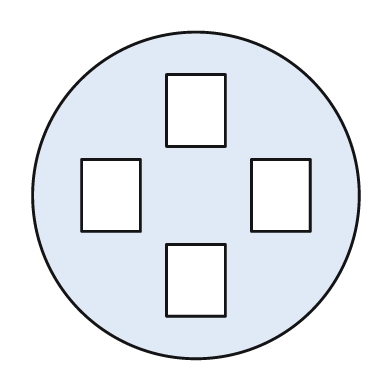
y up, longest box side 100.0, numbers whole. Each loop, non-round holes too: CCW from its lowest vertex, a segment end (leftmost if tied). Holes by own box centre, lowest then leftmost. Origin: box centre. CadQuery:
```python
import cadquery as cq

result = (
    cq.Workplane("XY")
    .moveTo(0.0, 0.0)
    .circle(50.0)
    .moveTo(-9.0, -37.0)
    .lineTo(9.0, -37.0)
    .lineTo(9.0, -15.0)
    .lineTo(-9.0, -15.0)
    .close()
    .moveTo(-35.0, -11.0)
    .lineTo(-17.0, -11.0)
    .lineTo(-17.0, 11.0)
    .lineTo(-35.0, 11.0)
    .close()
    .moveTo(17.0, -11.0)
    .lineTo(35.0, -11.0)
    .lineTo(35.0, 11.0)
    .lineTo(17.0, 11.0)
    .close()
    .moveTo(-9.0, 15.0)
    .lineTo(9.0, 15.0)
    .lineTo(9.0, 37.0)
    .lineTo(-9.0, 37.0)
    .close()
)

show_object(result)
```